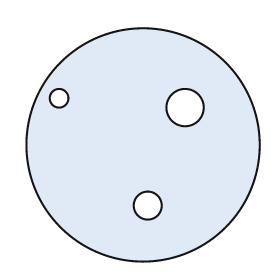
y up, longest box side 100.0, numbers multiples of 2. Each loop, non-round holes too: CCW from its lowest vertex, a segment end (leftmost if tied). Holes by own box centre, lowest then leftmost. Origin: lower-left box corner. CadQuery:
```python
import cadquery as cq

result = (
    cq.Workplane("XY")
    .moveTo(50.0, 50.0)
    .circle(50.0)
    .moveTo(52.0, 24.0)
    .circle(6.0)
    .moveTo(68.0, 66.0)
    .circle(8.0)
    .moveTo(14.0, 70.0)
    .circle(4.0)
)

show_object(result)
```